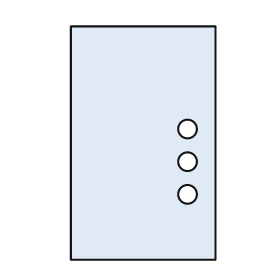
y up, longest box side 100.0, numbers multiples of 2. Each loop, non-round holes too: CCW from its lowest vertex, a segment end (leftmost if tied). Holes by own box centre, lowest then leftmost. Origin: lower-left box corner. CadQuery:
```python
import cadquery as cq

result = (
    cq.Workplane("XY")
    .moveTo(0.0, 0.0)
    .lineTo(62.0, 0.0)
    .lineTo(62.0, 100.0)
    .lineTo(0.0, 100.0)
    .close()
    .moveTo(50.0, 28.0)
    .circle(4.0)
    .moveTo(50.0, 42.0)
    .circle(4.0)
    .moveTo(50.0, 56.0)
    .circle(4.0)
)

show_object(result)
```